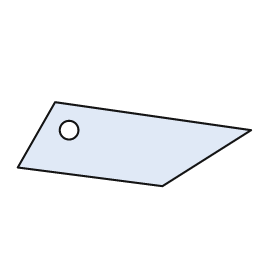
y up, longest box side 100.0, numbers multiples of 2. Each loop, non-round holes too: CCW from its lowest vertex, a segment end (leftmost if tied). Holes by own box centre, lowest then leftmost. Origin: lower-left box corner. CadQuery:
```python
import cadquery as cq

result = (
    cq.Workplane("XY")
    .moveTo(62.0, 0.0)
    .lineTo(100.0, 24.0)
    .lineTo(16.0, 36.0)
    .lineTo(0.0, 8.0)
    .close()
    .moveTo(22.0, 24.0)
    .circle(4.0)
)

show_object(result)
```